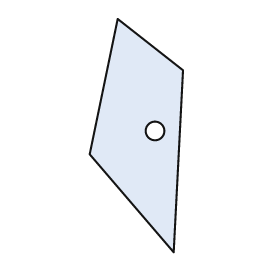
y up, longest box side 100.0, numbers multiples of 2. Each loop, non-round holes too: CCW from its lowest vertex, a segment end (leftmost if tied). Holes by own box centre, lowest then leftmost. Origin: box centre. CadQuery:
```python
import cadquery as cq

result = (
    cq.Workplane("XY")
    .moveTo(16.0, -50.0)
    .lineTo(20.0, 28.0)
    .lineTo(-8.0, 50.0)
    .lineTo(-20.0, -8.0)
    .close()
    .moveTo(8.0, 2.0)
    .circle(4.0)
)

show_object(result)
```